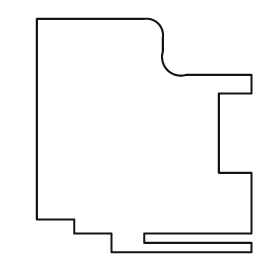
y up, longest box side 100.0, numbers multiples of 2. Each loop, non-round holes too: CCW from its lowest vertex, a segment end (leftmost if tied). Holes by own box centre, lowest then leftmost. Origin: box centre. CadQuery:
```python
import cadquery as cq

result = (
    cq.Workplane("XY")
    .moveTo(-14.0, -50.0)
    .lineTo(46.0, -50.0)
    .lineTo(46.0, -46.0)
    .lineTo(0.0, -46.0)
    .lineTo(0.0, -42.0)
    .lineTo(46.0, -42.0)
    .lineTo(46.0, -16.0)
    .lineTo(32.0, -16.0)
    .lineTo(32.0, 18.0)
    .lineTo(46.0, 18.0)
    .lineTo(46.0, 26.0)
    .lineTo(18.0, 26.0)
    .threePointArc((10.0, 28.0), (8.0, 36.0))
    .lineTo(8.0, 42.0)
    .threePointArc((6.0, 48.0), (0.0, 50.0))
    .lineTo(-46.0, 50.0)
    .lineTo(-46.0, -36.0)
    .lineTo(-30.0, -36.0)
    .lineTo(-30.0, -42.0)
    .lineTo(-14.0, -42.0)
    .close()
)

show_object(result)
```